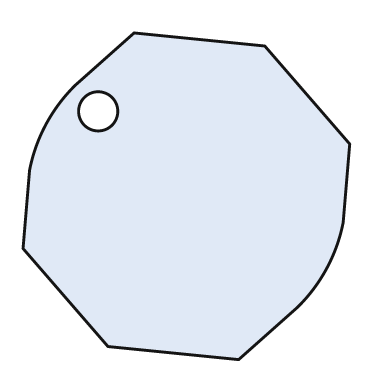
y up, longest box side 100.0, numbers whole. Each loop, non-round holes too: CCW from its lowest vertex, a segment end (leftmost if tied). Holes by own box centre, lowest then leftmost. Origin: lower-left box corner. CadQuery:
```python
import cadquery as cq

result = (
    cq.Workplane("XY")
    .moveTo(66.0, 0.0)
    .lineTo(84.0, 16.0)
    .threePointArc((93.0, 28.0), (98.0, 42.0))
    .lineTo(100.0, 66.0)
    .lineTo(74.0, 96.0)
    .lineTo(34.0, 100.0)
    .lineTo(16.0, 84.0)
    .threePointArc((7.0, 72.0), (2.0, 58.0))
    .lineTo(0.0, 34.0)
    .lineTo(26.0, 4.0)
    .close()
    .moveTo(23.0, 76.0)
    .circle(6.0)
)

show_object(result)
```